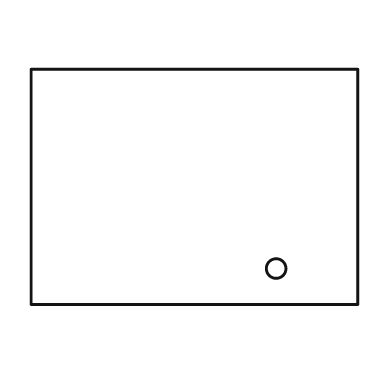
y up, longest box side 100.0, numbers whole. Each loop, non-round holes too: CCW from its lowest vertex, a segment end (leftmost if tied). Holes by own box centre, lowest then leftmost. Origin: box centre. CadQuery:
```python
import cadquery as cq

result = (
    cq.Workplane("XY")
    .moveTo(-50.0, -36.0)
    .lineTo(50.0, -36.0)
    .lineTo(50.0, 36.0)
    .lineTo(-50.0, 36.0)
    .close()
    .moveTo(25.0, -25.0)
    .circle(3.0)
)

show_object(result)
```